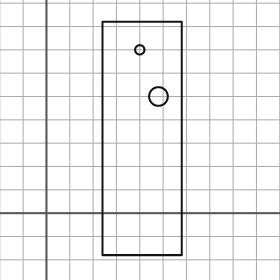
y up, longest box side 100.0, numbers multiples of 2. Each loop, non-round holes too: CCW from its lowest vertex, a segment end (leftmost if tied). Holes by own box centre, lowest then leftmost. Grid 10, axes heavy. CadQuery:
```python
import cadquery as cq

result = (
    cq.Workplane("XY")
    .moveTo(24.0, -18.0)
    .lineTo(58.0, -18.0)
    .lineTo(58.0, 82.0)
    .lineTo(24.0, 82.0)
    .close()
    .moveTo(48.0, 50.0)
    .circle(4.0)
    .moveTo(40.0, 70.0)
    .circle(2.0)
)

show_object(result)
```